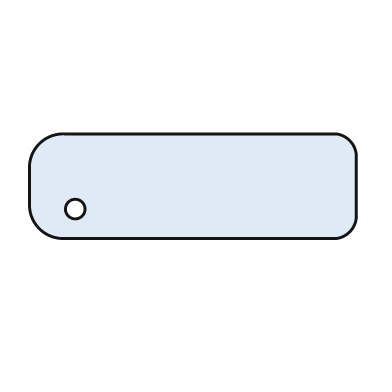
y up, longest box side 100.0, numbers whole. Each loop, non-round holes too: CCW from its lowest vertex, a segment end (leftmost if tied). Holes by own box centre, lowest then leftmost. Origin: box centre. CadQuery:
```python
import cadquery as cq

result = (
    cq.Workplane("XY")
    .moveTo(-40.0, -16.0)
    .lineTo(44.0, -16.0)
    .threePointArc((48.0, -14.0), (50.0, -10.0))
    .lineTo(50.0, 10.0)
    .threePointArc((48.0, 14.0), (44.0, 16.0))
    .lineTo(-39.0, 16.0)
    .threePointArc((-47.0, 13.0), (-50.0, 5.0))
    .lineTo(-50.0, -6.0)
    .threePointArc((-47.0, -13.0), (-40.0, -16.0))
    .close()
    .moveTo(-36.0, -7.0)
    .circle(3.0)
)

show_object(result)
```